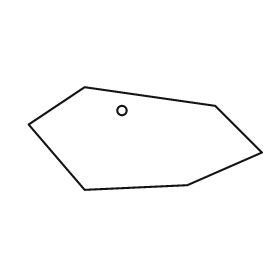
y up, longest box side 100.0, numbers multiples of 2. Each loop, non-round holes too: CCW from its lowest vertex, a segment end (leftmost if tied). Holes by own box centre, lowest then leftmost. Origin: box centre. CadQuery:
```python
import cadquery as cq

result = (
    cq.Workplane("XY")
    .moveTo(-26.0, -22.0)
    .lineTo(18.0, -20.0)
    .lineTo(50.0, -6.0)
    .lineTo(30.0, 14.0)
    .lineTo(-26.0, 22.0)
    .lineTo(-50.0, 6.0)
    .close()
    .moveTo(-10.0, 12.0)
    .circle(2.0)
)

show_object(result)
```